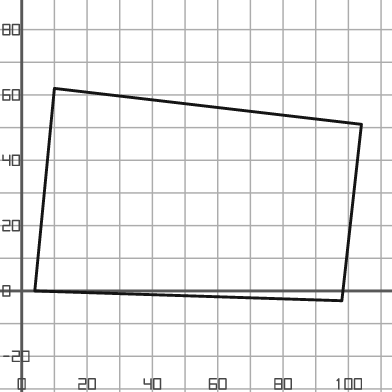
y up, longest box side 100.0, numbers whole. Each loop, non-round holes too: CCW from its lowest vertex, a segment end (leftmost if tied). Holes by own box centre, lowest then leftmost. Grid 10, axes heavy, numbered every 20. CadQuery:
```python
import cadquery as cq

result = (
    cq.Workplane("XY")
    .moveTo(98.0, -3.0)
    .lineTo(104.0, 51.0)
    .lineTo(10.0, 62.0)
    .lineTo(4.0, 0.0)
    .close()
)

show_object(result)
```